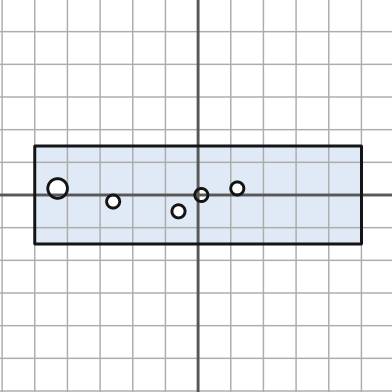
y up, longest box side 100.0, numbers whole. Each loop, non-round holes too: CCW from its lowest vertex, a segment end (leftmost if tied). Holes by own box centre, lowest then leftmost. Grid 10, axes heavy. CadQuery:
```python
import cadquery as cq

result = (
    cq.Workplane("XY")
    .moveTo(-50.0, -15.0)
    .lineTo(50.0, -15.0)
    .lineTo(50.0, 15.0)
    .lineTo(-50.0, 15.0)
    .close()
    .moveTo(-6.0, -5.0)
    .circle(2.0)
    .moveTo(-26.0, -2.0)
    .circle(2.0)
    .moveTo(1.0, 0.0)
    .circle(2.0)
    .moveTo(-43.0, 2.0)
    .circle(3.0)
    .moveTo(12.0, 2.0)
    .circle(2.0)
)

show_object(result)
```